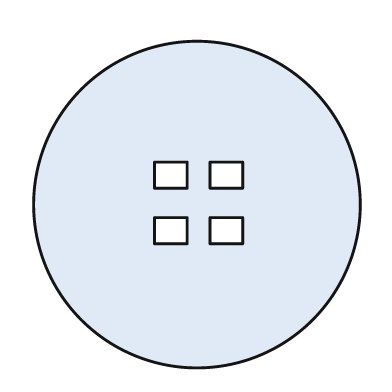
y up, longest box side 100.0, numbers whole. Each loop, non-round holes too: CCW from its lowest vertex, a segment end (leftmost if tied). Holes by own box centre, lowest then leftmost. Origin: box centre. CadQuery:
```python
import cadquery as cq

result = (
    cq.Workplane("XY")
    .moveTo(0.0, 0.0)
    .circle(50.0)
    .moveTo(-13.0, -12.0)
    .lineTo(-3.0, -12.0)
    .lineTo(-3.0, -4.0)
    .lineTo(-13.0, -4.0)
    .close()
    .moveTo(4.0, -12.0)
    .lineTo(14.0, -12.0)
    .lineTo(14.0, -4.0)
    .lineTo(4.0, -4.0)
    .close()
    .moveTo(-13.0, 5.0)
    .lineTo(-3.0, 5.0)
    .lineTo(-3.0, 13.0)
    .lineTo(-13.0, 13.0)
    .close()
    .moveTo(4.0, 5.0)
    .lineTo(14.0, 5.0)
    .lineTo(14.0, 13.0)
    .lineTo(4.0, 13.0)
    .close()
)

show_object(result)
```